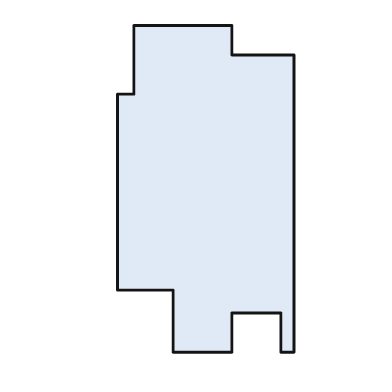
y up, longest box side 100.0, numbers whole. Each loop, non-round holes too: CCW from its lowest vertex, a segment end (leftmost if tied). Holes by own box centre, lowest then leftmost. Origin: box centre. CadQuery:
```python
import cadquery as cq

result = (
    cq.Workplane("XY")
    .moveTo(-10.0, -50.0)
    .lineTo(8.0, -50.0)
    .lineTo(8.0, -38.0)
    .lineTo(23.0, -38.0)
    .lineTo(23.0, -50.0)
    .lineTo(27.0, -50.0)
    .lineTo(27.0, 41.0)
    .lineTo(8.0, 41.0)
    .lineTo(8.0, 50.0)
    .lineTo(-22.0, 50.0)
    .lineTo(-22.0, 29.0)
    .lineTo(-27.0, 29.0)
    .lineTo(-27.0, -31.0)
    .lineTo(-10.0, -31.0)
    .close()
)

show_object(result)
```